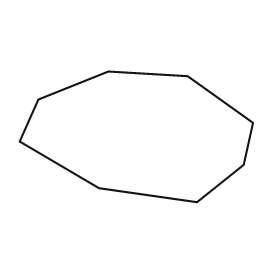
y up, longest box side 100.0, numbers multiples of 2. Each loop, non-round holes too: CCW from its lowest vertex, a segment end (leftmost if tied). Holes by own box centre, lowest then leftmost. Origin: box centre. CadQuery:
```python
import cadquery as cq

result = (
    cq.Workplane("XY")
    .moveTo(26.0, -28.0)
    .lineTo(46.0, -12.0)
    .lineTo(50.0, 6.0)
    .lineTo(22.0, 26.0)
    .lineTo(-12.0, 28.0)
    .lineTo(-42.0, 16.0)
    .lineTo(-50.0, -2.0)
    .lineTo(-16.0, -22.0)
    .close()
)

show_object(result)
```